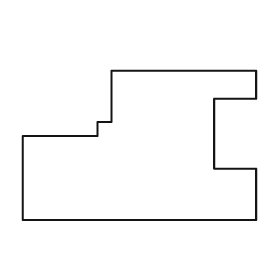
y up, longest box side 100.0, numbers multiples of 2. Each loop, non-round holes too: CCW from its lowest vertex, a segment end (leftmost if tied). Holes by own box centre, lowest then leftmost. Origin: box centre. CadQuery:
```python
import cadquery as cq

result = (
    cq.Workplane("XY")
    .moveTo(-50.0, -32.0)
    .lineTo(50.0, -32.0)
    .lineTo(50.0, -10.0)
    .lineTo(32.0, -10.0)
    .lineTo(32.0, 20.0)
    .lineTo(50.0, 20.0)
    .lineTo(50.0, 32.0)
    .lineTo(-12.0, 32.0)
    .lineTo(-12.0, 10.0)
    .lineTo(-18.0, 10.0)
    .lineTo(-18.0, 4.0)
    .lineTo(-50.0, 4.0)
    .close()
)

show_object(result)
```